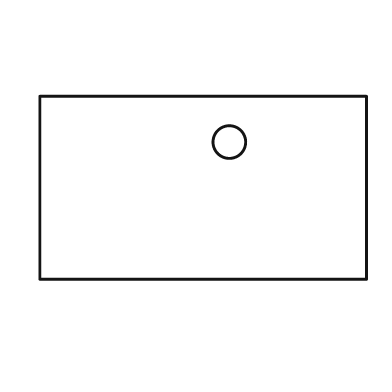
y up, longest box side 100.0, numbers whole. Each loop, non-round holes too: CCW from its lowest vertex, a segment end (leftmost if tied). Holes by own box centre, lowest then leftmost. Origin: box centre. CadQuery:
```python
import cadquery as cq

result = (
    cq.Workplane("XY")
    .moveTo(-50.0, -28.0)
    .lineTo(50.0, -28.0)
    .lineTo(50.0, 28.0)
    .lineTo(-50.0, 28.0)
    .close()
    .moveTo(8.0, 14.0)
    .circle(5.0)
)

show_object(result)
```